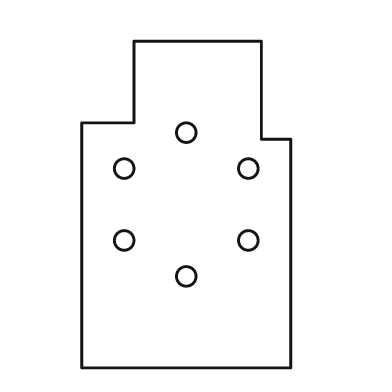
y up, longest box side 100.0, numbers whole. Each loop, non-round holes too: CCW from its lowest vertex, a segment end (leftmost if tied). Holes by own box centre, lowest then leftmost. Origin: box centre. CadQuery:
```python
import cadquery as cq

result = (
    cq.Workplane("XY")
    .moveTo(-32.0, -50.0)
    .lineTo(32.0, -50.0)
    .lineTo(32.0, 20.0)
    .lineTo(23.0, 20.0)
    .lineTo(23.0, 50.0)
    .lineTo(-16.0, 50.0)
    .lineTo(-16.0, 25.0)
    .lineTo(-32.0, 25.0)
    .close()
    .moveTo(0.0, -22.0)
    .circle(3.0)
    .moveTo(-19.0, -11.0)
    .circle(3.0)
    .moveTo(19.0, -11.0)
    .circle(3.0)
    .moveTo(-19.0, 11.0)
    .circle(3.0)
    .moveTo(19.0, 11.0)
    .circle(3.0)
    .moveTo(0.0, 22.0)
    .circle(3.0)
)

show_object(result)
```